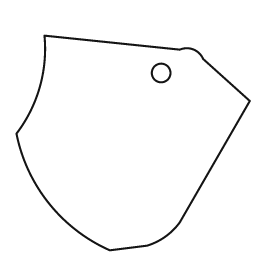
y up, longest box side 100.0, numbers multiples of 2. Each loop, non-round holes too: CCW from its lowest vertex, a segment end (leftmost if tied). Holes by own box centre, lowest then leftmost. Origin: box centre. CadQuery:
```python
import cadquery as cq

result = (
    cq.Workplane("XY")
    .moveTo(-10.0, -46.0)
    .lineTo(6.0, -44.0)
    .threePointArc((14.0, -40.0), (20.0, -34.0))
    .lineTo(50.0, 18.0)
    .lineTo(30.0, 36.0)
    .threePointArc((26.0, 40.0), (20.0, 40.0))
    .lineTo(-38.0, 46.0)
    .threePointArc((-40.0, 24.0), (-50.0, 4.0))
    .threePointArc((-36.0, -26.0), (-10.0, -46.0))
    .close()
    .moveTo(12.0, 30.0)
    .circle(4.0)
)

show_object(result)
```